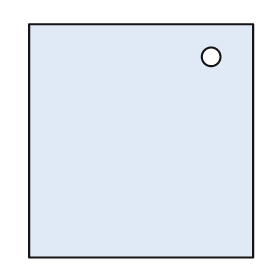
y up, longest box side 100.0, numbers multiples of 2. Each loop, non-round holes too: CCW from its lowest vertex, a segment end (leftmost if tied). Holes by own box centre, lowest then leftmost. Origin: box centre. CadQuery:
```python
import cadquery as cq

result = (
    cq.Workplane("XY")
    .moveTo(-48.0, -50.0)
    .lineTo(48.0, -50.0)
    .lineTo(48.0, 50.0)
    .lineTo(-48.0, 50.0)
    .close()
    .moveTo(30.0, 36.0)
    .circle(4.0)
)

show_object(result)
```